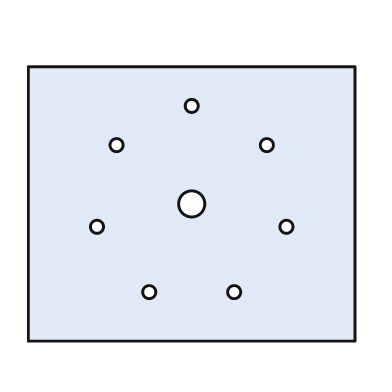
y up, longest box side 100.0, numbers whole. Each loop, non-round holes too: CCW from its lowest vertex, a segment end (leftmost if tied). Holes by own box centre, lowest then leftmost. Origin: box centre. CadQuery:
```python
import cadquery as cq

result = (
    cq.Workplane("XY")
    .moveTo(-50.0, -42.0)
    .lineTo(50.0, -42.0)
    .lineTo(50.0, 42.0)
    .lineTo(-50.0, 42.0)
    .close()
    .moveTo(-13.0, -27.0)
    .circle(2.0)
    .moveTo(13.0, -27.0)
    .circle(2.0)
    .moveTo(-29.0, -7.0)
    .circle(2.0)
    .moveTo(29.0, -7.0)
    .circle(2.0)
    .moveTo(0.0, 0.0)
    .circle(4.0)
    .moveTo(-23.0, 18.0)
    .circle(2.0)
    .moveTo(23.0, 18.0)
    .circle(2.0)
    .moveTo(0.0, 30.0)
    .circle(2.0)
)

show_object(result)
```